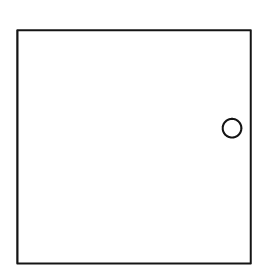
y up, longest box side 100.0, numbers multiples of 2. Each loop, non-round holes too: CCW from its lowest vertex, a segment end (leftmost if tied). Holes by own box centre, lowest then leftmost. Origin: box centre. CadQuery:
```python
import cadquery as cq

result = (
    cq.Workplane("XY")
    .moveTo(-50.0, -50.0)
    .lineTo(50.0, -50.0)
    .lineTo(50.0, 50.0)
    .lineTo(-50.0, 50.0)
    .close()
    .moveTo(42.0, 8.0)
    .circle(4.0)
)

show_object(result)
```